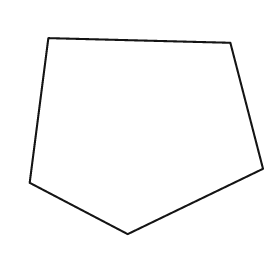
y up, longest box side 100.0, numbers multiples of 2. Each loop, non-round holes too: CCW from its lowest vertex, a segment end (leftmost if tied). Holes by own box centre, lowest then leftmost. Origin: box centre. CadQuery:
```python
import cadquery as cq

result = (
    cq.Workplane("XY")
    .moveTo(-8.0, -42.0)
    .lineTo(50.0, -14.0)
    .lineTo(36.0, 40.0)
    .lineTo(-42.0, 42.0)
    .lineTo(-50.0, -20.0)
    .close()
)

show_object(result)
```